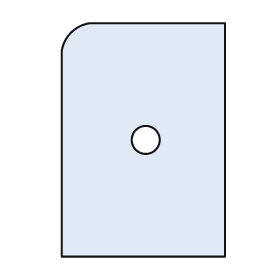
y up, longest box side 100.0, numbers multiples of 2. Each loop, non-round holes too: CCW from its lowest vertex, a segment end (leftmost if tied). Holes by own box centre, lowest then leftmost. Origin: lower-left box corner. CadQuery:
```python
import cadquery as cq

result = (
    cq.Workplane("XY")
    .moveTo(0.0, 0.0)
    .lineTo(70.0, 0.0)
    .lineTo(70.0, 100.0)
    .lineTo(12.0, 100.0)
    .threePointArc((4.0, 96.0), (0.0, 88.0))
    .close()
    .moveTo(36.0, 50.0)
    .circle(6.0)
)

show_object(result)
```